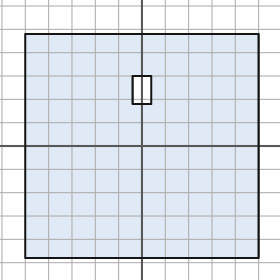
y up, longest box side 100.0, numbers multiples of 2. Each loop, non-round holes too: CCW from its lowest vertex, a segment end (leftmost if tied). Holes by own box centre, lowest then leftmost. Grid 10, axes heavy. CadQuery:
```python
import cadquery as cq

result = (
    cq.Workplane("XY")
    .moveTo(-50.0, -48.0)
    .lineTo(50.0, -48.0)
    .lineTo(50.0, 48.0)
    .lineTo(-50.0, 48.0)
    .close()
    .moveTo(-4.0, 18.0)
    .lineTo(4.0, 18.0)
    .lineTo(4.0, 30.0)
    .lineTo(-4.0, 30.0)
    .close()
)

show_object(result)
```